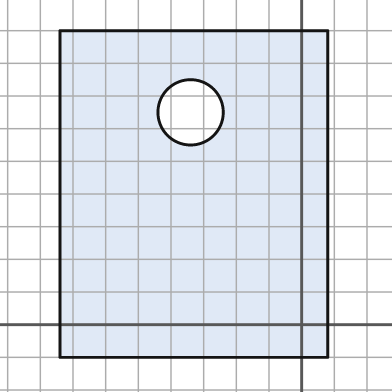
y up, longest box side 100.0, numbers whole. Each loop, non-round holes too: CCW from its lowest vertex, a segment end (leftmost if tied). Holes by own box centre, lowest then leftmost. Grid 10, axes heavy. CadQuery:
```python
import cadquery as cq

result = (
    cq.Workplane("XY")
    .moveTo(-74.0, -10.0)
    .lineTo(8.0, -10.0)
    .lineTo(8.0, 90.0)
    .lineTo(-74.0, 90.0)
    .close()
    .moveTo(-34.0, 65.0)
    .circle(10.0)
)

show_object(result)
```